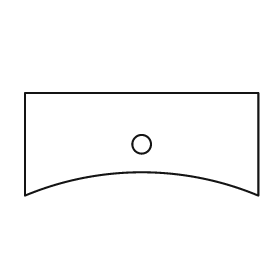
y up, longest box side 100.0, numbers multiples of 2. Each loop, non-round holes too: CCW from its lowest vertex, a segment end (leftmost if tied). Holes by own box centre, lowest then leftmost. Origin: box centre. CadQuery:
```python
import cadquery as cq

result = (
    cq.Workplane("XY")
    .moveTo(-50.0, -22.0)
    .threePointArc((0.0, -12.0), (50.0, -22.0))
    .lineTo(50.0, 22.0)
    .lineTo(-50.0, 22.0)
    .close()
    .moveTo(0.0, 0.0)
    .circle(4.0)
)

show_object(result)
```